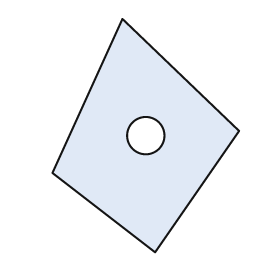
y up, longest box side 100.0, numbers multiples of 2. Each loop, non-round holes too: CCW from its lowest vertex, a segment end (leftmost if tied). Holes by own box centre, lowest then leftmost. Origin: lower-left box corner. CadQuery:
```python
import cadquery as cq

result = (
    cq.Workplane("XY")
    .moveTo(44.0, 0.0)
    .lineTo(80.0, 52.0)
    .lineTo(30.0, 100.0)
    .lineTo(0.0, 34.0)
    .close()
    .moveTo(40.0, 50.0)
    .circle(8.0)
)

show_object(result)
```